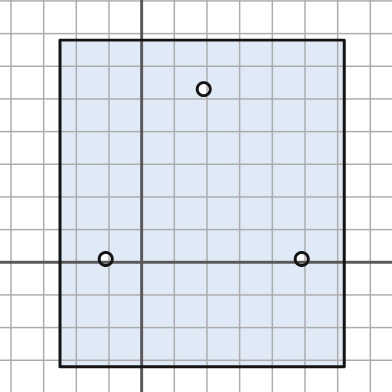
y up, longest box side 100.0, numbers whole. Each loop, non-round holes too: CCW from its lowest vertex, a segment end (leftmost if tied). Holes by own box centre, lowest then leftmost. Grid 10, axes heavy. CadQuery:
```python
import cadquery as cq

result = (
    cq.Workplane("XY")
    .moveTo(-25.0, -32.0)
    .lineTo(62.0, -32.0)
    .lineTo(62.0, 68.0)
    .lineTo(-25.0, 68.0)
    .close()
    .moveTo(-11.0, 1.0)
    .circle(2.0)
    .moveTo(49.0, 1.0)
    .circle(2.0)
    .moveTo(19.0, 53.0)
    .circle(2.0)
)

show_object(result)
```